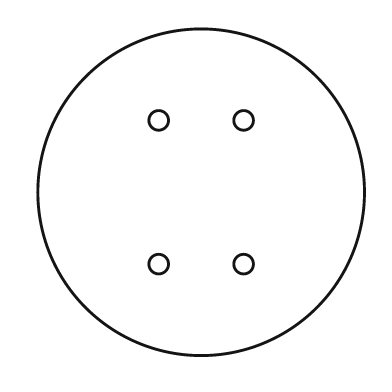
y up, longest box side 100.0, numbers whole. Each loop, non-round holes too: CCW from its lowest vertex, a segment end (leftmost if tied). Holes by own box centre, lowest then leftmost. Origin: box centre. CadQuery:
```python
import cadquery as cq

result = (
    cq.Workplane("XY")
    .moveTo(0.0, 0.0)
    .circle(50.0)
    .moveTo(-13.0, -22.0)
    .circle(3.0)
    .moveTo(13.0, -22.0)
    .circle(3.0)
    .moveTo(-13.0, 22.0)
    .circle(3.0)
    .moveTo(13.0, 22.0)
    .circle(3.0)
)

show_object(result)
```